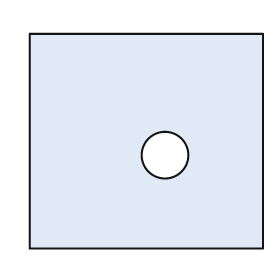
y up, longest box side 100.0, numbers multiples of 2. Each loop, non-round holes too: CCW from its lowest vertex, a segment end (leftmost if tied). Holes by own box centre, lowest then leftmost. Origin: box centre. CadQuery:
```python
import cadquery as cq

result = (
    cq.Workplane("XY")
    .moveTo(-50.0, -46.0)
    .lineTo(50.0, -46.0)
    .lineTo(50.0, 46.0)
    .lineTo(-50.0, 46.0)
    .close()
    .moveTo(8.0, -6.0)
    .circle(10.0)
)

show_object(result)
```